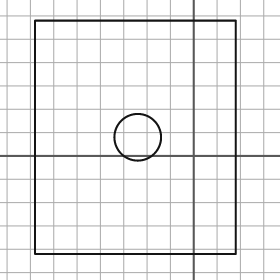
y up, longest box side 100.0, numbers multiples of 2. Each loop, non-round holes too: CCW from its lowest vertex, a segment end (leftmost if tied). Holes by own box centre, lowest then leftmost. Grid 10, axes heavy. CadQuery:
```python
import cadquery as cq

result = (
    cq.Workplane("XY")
    .moveTo(-68.0, -42.0)
    .lineTo(18.0, -42.0)
    .lineTo(18.0, 58.0)
    .lineTo(-68.0, 58.0)
    .close()
    .moveTo(-24.0, 8.0)
    .circle(10.0)
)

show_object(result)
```